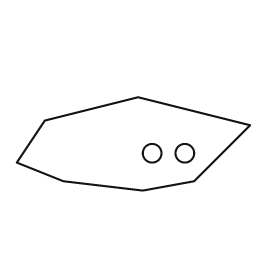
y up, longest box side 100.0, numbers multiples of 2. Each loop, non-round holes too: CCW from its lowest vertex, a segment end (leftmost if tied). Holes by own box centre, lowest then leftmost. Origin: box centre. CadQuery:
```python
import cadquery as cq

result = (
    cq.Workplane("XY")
    .moveTo(4.0, -20.0)
    .lineTo(26.0, -16.0)
    .lineTo(50.0, 8.0)
    .lineTo(2.0, 20.0)
    .lineTo(-38.0, 10.0)
    .lineTo(-50.0, -8.0)
    .lineTo(-30.0, -16.0)
    .close()
    .moveTo(8.0, -4.0)
    .circle(4.0)
    .moveTo(22.0, -4.0)
    .circle(4.0)
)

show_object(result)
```